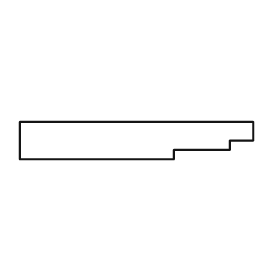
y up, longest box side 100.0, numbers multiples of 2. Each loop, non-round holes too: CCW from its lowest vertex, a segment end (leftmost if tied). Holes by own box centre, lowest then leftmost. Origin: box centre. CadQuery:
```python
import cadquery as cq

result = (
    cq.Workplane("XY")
    .moveTo(-50.0, -8.0)
    .lineTo(16.0, -8.0)
    .lineTo(16.0, -4.0)
    .lineTo(40.0, -4.0)
    .lineTo(40.0, 0.0)
    .lineTo(50.0, 0.0)
    .lineTo(50.0, 8.0)
    .lineTo(-50.0, 8.0)
    .close()
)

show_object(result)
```